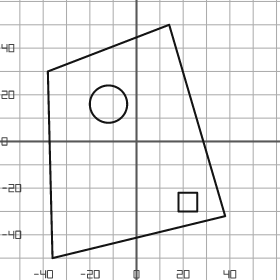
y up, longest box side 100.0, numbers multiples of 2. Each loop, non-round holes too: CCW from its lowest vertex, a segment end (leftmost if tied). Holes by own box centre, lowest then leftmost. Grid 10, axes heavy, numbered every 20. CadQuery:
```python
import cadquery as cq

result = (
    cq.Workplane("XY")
    .moveTo(-36.0, -50.0)
    .lineTo(38.0, -32.0)
    .lineTo(14.0, 50.0)
    .lineTo(-38.0, 30.0)
    .close()
    .moveTo(18.0, -30.0)
    .lineTo(26.0, -30.0)
    .lineTo(26.0, -22.0)
    .lineTo(18.0, -22.0)
    .close()
    .moveTo(-12.0, 16.0)
    .circle(8.0)
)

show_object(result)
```